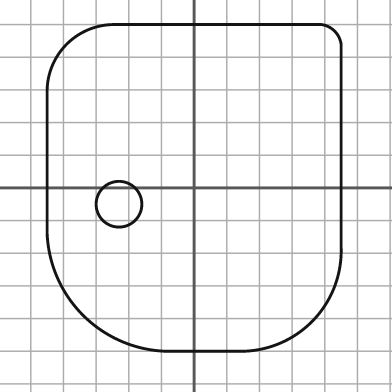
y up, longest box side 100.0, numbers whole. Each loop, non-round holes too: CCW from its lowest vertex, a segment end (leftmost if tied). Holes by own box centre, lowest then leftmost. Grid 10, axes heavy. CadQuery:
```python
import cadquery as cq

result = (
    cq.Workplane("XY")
    .moveTo(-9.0, -50.0)
    .lineTo(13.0, -50.0)
    .threePointArc((36.0, -41.0), (45.0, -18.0))
    .lineTo(45.0, 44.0)
    .threePointArc((43.0, 48.0), (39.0, 50.0))
    .lineTo(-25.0, 50.0)
    .threePointArc((-39.0, 44.0), (-45.0, 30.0))
    .lineTo(-45.0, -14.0)
    .threePointArc((-34.0, -39.0), (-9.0, -50.0))
    .close()
    .moveTo(-23.0, -5.0)
    .circle(7.0)
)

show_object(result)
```